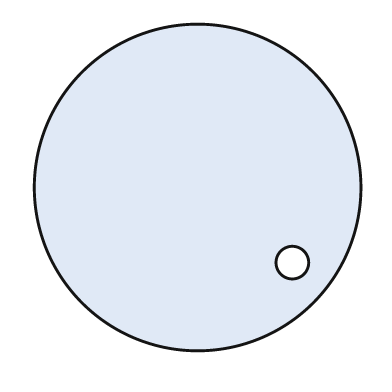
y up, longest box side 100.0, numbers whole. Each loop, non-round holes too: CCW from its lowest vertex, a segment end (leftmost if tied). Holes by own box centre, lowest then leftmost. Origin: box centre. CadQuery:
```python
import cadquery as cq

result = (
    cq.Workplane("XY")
    .moveTo(0.0, 0.0)
    .circle(50.0)
    .moveTo(29.0, -23.0)
    .circle(5.0)
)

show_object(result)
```